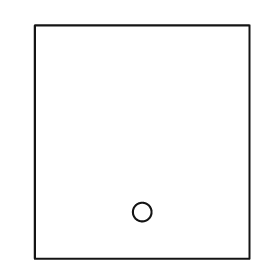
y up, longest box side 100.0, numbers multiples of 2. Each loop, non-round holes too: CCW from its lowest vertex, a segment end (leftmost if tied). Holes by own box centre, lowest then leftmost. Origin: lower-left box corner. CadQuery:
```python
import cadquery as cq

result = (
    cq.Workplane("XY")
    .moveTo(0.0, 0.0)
    .lineTo(92.0, 0.0)
    .lineTo(92.0, 100.0)
    .lineTo(0.0, 100.0)
    .close()
    .moveTo(46.0, 20.0)
    .circle(4.0)
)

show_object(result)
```